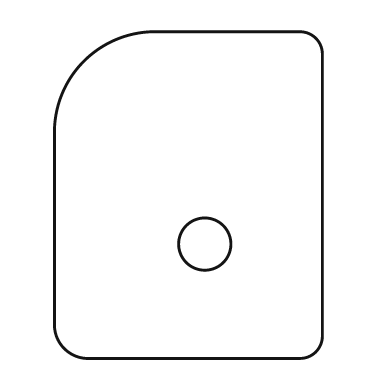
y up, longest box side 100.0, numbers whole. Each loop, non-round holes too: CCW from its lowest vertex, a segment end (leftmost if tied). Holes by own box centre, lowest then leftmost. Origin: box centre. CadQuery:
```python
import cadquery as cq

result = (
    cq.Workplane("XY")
    .moveTo(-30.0, -50.0)
    .lineTo(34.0, -50.0)
    .threePointArc((39.0, -48.0), (41.0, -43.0))
    .lineTo(41.0, 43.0)
    .threePointArc((39.0, 48.0), (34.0, 50.0))
    .lineTo(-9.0, 50.0)
    .threePointArc((-32.0, 41.0), (-41.0, 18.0))
    .lineTo(-41.0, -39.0)
    .threePointArc((-38.0, -47.0), (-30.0, -50.0))
    .close()
    .moveTo(5.0, -15.0)
    .circle(8.0)
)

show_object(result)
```